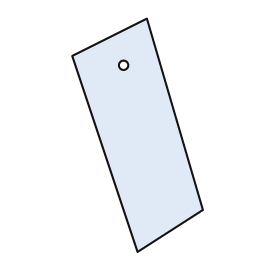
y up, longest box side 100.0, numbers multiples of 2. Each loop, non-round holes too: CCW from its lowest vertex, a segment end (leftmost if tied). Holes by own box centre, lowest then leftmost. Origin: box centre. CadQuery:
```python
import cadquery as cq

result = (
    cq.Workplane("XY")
    .moveTo(0.0, -50.0)
    .lineTo(28.0, -32.0)
    .lineTo(4.0, 50.0)
    .lineTo(-28.0, 34.0)
    .close()
    .moveTo(-6.0, 30.0)
    .circle(2.0)
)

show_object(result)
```